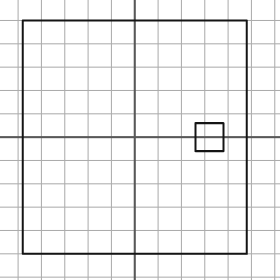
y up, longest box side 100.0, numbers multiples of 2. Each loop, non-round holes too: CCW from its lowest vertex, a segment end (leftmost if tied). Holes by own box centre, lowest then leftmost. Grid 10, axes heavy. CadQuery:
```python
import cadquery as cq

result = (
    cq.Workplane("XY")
    .moveTo(-48.0, -50.0)
    .lineTo(48.0, -50.0)
    .lineTo(48.0, 50.0)
    .lineTo(-48.0, 50.0)
    .close()
    .moveTo(26.0, -6.0)
    .lineTo(38.0, -6.0)
    .lineTo(38.0, 6.0)
    .lineTo(26.0, 6.0)
    .close()
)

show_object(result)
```